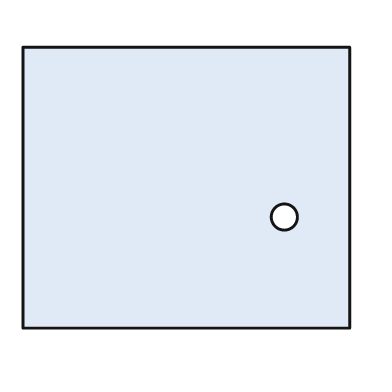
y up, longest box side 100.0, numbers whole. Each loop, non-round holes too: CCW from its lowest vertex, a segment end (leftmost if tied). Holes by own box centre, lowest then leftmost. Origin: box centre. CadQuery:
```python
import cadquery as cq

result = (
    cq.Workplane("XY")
    .moveTo(-50.0, -43.0)
    .lineTo(50.0, -43.0)
    .lineTo(50.0, 43.0)
    .lineTo(-50.0, 43.0)
    .close()
    .moveTo(30.0, -9.0)
    .circle(4.0)
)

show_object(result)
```